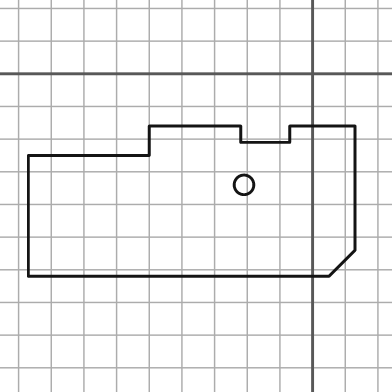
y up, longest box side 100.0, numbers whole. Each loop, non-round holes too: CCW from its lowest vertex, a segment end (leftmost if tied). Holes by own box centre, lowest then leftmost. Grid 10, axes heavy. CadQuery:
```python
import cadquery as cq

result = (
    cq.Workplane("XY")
    .moveTo(-87.0, -62.0)
    .lineTo(5.0, -62.0)
    .lineTo(13.0, -54.0)
    .lineTo(13.0, -16.0)
    .lineTo(-7.0, -16.0)
    .lineTo(-7.0, -21.0)
    .lineTo(-22.0, -21.0)
    .lineTo(-22.0, -16.0)
    .lineTo(-50.0, -16.0)
    .lineTo(-50.0, -25.0)
    .lineTo(-87.0, -25.0)
    .close()
    .moveTo(-21.0, -34.0)
    .circle(3.0)
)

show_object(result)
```